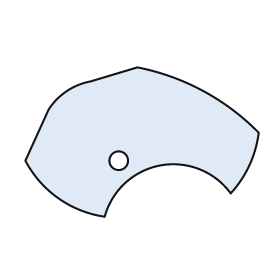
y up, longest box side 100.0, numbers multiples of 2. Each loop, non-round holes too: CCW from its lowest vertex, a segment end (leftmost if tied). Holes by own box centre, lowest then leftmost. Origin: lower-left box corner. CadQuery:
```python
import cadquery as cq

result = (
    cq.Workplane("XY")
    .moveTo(34.0, 0.0)
    .threePointArc((58.0, 22.0), (88.0, 10.0))
    .threePointArc((96.0, 22.0), (100.0, 36.0))
    .threePointArc((76.0, 54.0), (48.0, 64.0))
    .lineTo(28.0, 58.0)
    .threePointArc((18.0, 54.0), (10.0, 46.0))
    .lineTo(0.0, 24.0)
    .threePointArc((14.0, 8.0), (34.0, 0.0))
    .close()
    .moveTo(40.0, 24.0)
    .circle(4.0)
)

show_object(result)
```